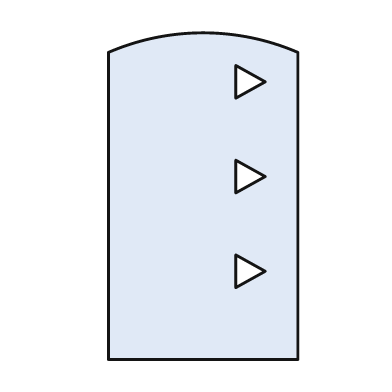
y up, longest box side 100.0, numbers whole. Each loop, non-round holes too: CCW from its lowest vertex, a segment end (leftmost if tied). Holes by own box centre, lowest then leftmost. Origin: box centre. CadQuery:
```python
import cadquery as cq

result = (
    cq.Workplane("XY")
    .moveTo(-29.0, -50.0)
    .lineTo(29.0, -50.0)
    .lineTo(29.0, 44.0)
    .threePointArc((0.0, 50.0), (-29.0, 44.0))
    .close()
    .moveTo(10.0, -28.0)
    .lineTo(19.0, -23.0)
    .lineTo(10.0, -18.0)
    .close()
    .moveTo(10.0, 1.0)
    .lineTo(19.0, 6.0)
    .lineTo(10.0, 11.0)
    .close()
    .moveTo(10.0, 30.0)
    .lineTo(19.0, 35.0)
    .lineTo(10.0, 40.0)
    .close()
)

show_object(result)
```